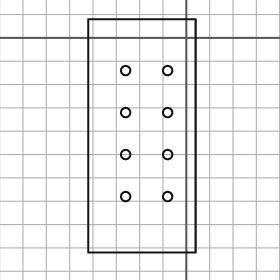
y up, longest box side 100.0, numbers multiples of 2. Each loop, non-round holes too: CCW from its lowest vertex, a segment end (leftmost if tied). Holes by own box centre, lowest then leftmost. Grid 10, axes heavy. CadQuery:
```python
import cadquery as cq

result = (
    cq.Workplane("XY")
    .moveTo(-42.0, -92.0)
    .lineTo(4.0, -92.0)
    .lineTo(4.0, 8.0)
    .lineTo(-42.0, 8.0)
    .close()
    .moveTo(-26.0, -68.0)
    .circle(2.0)
    .moveTo(-8.0, -68.0)
    .circle(2.0)
    .moveTo(-26.0, -50.0)
    .circle(2.0)
    .moveTo(-8.0, -50.0)
    .circle(2.0)
    .moveTo(-26.0, -32.0)
    .circle(2.0)
    .moveTo(-8.0, -32.0)
    .circle(2.0)
    .moveTo(-26.0, -14.0)
    .circle(2.0)
    .moveTo(-8.0, -14.0)
    .circle(2.0)
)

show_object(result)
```